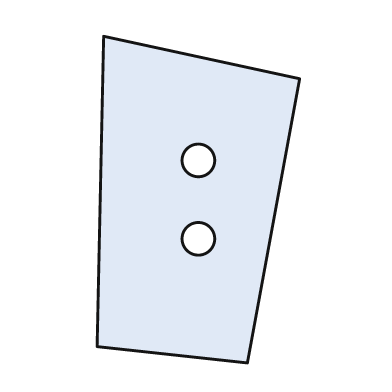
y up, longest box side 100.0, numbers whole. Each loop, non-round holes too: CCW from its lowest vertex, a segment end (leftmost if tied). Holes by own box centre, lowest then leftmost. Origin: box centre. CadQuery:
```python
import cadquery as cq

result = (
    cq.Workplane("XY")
    .moveTo(15.0, -50.0)
    .lineTo(31.0, 37.0)
    .lineTo(-29.0, 50.0)
    .lineTo(-31.0, -45.0)
    .close()
    .moveTo(0.0, -12.0)
    .circle(5.0)
    .moveTo(0.0, 12.0)
    .circle(5.0)
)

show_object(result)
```